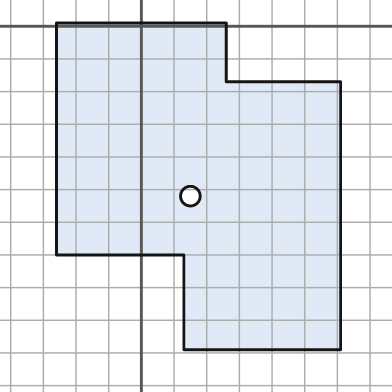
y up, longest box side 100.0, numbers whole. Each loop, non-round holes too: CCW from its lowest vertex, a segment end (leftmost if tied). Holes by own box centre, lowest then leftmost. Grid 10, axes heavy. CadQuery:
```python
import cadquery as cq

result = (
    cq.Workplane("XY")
    .moveTo(13.0, -99.0)
    .lineTo(61.0, -99.0)
    .lineTo(61.0, -17.0)
    .lineTo(26.0, -17.0)
    .lineTo(26.0, 1.0)
    .lineTo(-26.0, 1.0)
    .lineTo(-26.0, -70.0)
    .lineTo(13.0, -70.0)
    .close()
    .moveTo(15.0, -52.0)
    .circle(3.0)
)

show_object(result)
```